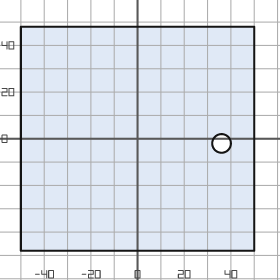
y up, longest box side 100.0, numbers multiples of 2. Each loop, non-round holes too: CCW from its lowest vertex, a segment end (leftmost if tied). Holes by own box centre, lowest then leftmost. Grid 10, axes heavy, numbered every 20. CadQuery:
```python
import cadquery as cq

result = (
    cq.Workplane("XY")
    .moveTo(-50.0, -48.0)
    .lineTo(50.0, -48.0)
    .lineTo(50.0, 48.0)
    .lineTo(-50.0, 48.0)
    .close()
    .moveTo(36.0, -2.0)
    .circle(4.0)
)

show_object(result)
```